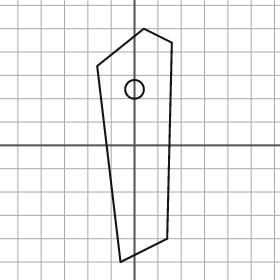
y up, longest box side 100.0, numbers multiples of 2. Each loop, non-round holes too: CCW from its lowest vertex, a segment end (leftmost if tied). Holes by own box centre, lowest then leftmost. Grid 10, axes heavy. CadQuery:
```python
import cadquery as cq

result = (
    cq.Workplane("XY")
    .moveTo(-6.0, -50.0)
    .lineTo(14.0, -40.0)
    .lineTo(16.0, 44.0)
    .lineTo(4.0, 50.0)
    .lineTo(-16.0, 34.0)
    .close()
    .moveTo(0.0, 24.0)
    .circle(4.0)
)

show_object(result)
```